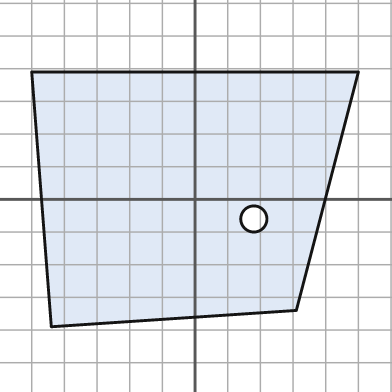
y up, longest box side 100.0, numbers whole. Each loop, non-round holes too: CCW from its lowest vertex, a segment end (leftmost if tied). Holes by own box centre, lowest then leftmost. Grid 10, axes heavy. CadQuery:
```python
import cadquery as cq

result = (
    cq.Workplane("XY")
    .moveTo(-44.0, -39.0)
    .lineTo(31.0, -34.0)
    .lineTo(50.0, 39.0)
    .lineTo(-50.0, 39.0)
    .close()
    .moveTo(18.0, -6.0)
    .circle(4.0)
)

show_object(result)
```